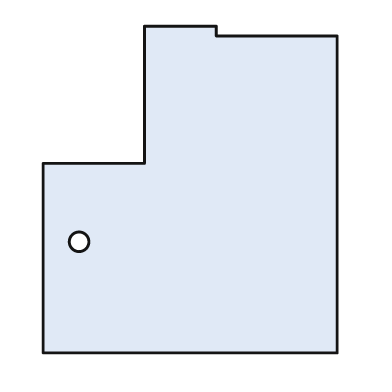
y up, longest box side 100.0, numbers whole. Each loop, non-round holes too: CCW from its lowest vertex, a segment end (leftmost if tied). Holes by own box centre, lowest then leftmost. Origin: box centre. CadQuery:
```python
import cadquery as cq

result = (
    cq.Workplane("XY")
    .moveTo(-45.0, -50.0)
    .lineTo(45.0, -50.0)
    .lineTo(45.0, 47.0)
    .lineTo(8.0, 47.0)
    .lineTo(8.0, 50.0)
    .lineTo(-14.0, 50.0)
    .lineTo(-14.0, 8.0)
    .lineTo(-45.0, 8.0)
    .close()
    .moveTo(-34.0, -16.0)
    .circle(3.0)
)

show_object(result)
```